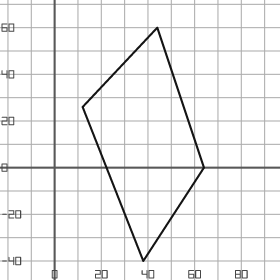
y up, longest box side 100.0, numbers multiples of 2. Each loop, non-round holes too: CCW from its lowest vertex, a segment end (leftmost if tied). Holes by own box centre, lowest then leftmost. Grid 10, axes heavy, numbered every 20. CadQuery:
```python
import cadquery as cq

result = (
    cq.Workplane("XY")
    .moveTo(38.0, -40.0)
    .lineTo(64.0, 0.0)
    .lineTo(44.0, 60.0)
    .lineTo(12.0, 26.0)
    .close()
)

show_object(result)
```